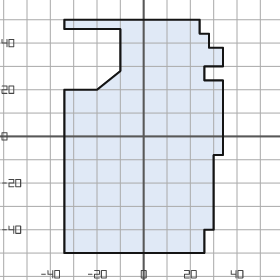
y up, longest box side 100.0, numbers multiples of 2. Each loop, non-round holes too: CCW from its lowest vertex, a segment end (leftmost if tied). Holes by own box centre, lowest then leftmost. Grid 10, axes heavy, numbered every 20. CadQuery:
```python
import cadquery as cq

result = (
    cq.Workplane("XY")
    .moveTo(-34.0, -50.0)
    .lineTo(26.0, -50.0)
    .lineTo(26.0, -40.0)
    .lineTo(30.0, -40.0)
    .lineTo(30.0, -8.0)
    .lineTo(34.0, -8.0)
    .lineTo(34.0, 24.0)
    .lineTo(26.0, 24.0)
    .lineTo(26.0, 30.0)
    .lineTo(34.0, 30.0)
    .lineTo(34.0, 38.0)
    .lineTo(28.0, 38.0)
    .lineTo(28.0, 44.0)
    .lineTo(24.0, 44.0)
    .lineTo(24.0, 50.0)
    .lineTo(-34.0, 50.0)
    .lineTo(-34.0, 46.0)
    .lineTo(-10.0, 46.0)
    .lineTo(-10.0, 28.0)
    .lineTo(-20.0, 20.0)
    .lineTo(-34.0, 20.0)
    .close()
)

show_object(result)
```